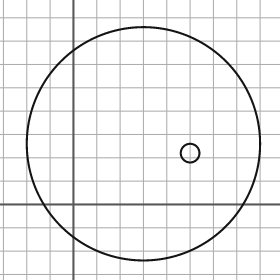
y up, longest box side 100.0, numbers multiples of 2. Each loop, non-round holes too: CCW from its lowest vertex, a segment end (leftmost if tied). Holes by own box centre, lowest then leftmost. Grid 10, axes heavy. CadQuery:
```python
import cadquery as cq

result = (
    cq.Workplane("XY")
    .moveTo(30.0, 26.0)
    .circle(50.0)
    .moveTo(50.0, 22.0)
    .circle(4.0)
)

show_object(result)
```